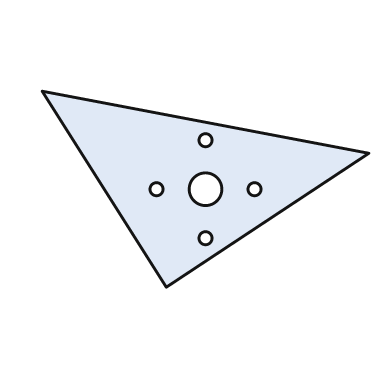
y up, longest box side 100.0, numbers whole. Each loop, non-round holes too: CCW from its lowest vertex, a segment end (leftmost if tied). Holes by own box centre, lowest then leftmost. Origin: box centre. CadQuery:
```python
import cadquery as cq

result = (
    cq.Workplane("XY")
    .moveTo(-12.0, -30.0)
    .lineTo(50.0, 11.0)
    .lineTo(-50.0, 30.0)
    .close()
    .moveTo(0.0, -15.0)
    .circle(2.0)
    .moveTo(-15.0, 0.0)
    .circle(2.0)
    .moveTo(0.0, 0.0)
    .circle(5.0)
    .moveTo(15.0, 0.0)
    .circle(2.0)
    .moveTo(0.0, 15.0)
    .circle(2.0)
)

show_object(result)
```